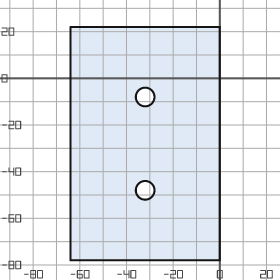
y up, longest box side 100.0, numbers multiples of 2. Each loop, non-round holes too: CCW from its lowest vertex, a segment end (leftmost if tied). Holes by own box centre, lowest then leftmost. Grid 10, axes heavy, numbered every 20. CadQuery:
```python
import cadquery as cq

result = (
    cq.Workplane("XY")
    .moveTo(-64.0, -78.0)
    .lineTo(0.0, -78.0)
    .lineTo(0.0, 22.0)
    .lineTo(-64.0, 22.0)
    .close()
    .moveTo(-32.0, -48.0)
    .circle(4.0)
    .moveTo(-32.0, -8.0)
    .circle(4.0)
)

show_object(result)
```